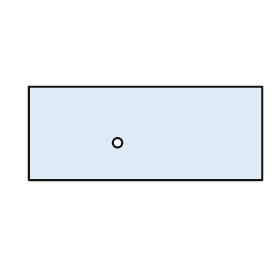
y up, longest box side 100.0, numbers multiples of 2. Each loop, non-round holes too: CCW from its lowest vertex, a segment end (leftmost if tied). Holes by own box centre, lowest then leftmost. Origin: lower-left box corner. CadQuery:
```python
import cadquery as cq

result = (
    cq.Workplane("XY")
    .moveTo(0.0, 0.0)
    .lineTo(100.0, 0.0)
    .lineTo(100.0, 40.0)
    .lineTo(0.0, 40.0)
    .close()
    .moveTo(38.0, 16.0)
    .circle(2.0)
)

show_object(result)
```